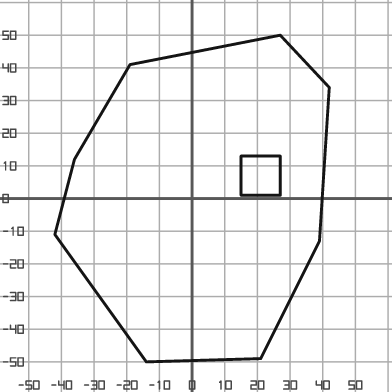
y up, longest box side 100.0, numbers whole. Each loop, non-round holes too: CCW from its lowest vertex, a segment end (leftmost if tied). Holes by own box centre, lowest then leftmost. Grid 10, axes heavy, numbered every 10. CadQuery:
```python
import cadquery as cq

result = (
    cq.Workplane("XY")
    .moveTo(-14.0, -50.0)
    .lineTo(21.0, -49.0)
    .lineTo(39.0, -13.0)
    .lineTo(42.0, 34.0)
    .lineTo(27.0, 50.0)
    .lineTo(-19.0, 41.0)
    .lineTo(-36.0, 12.0)
    .lineTo(-42.0, -11.0)
    .close()
    .moveTo(15.0, 1.0)
    .lineTo(27.0, 1.0)
    .lineTo(27.0, 13.0)
    .lineTo(15.0, 13.0)
    .close()
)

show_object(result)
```